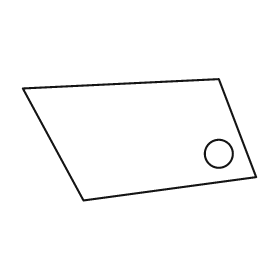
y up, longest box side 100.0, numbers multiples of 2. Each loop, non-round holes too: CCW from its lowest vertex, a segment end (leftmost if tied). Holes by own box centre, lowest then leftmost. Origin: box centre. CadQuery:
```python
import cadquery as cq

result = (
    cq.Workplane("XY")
    .moveTo(-24.0, -26.0)
    .lineTo(50.0, -16.0)
    .lineTo(34.0, 26.0)
    .lineTo(-50.0, 22.0)
    .close()
    .moveTo(34.0, -6.0)
    .circle(6.0)
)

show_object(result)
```